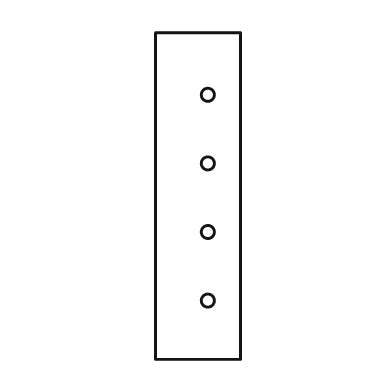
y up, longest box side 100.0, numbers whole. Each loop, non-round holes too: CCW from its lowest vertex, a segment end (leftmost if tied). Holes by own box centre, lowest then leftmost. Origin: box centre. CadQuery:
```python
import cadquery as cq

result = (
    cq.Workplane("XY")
    .moveTo(-13.0, -50.0)
    .lineTo(13.0, -50.0)
    .lineTo(13.0, 50.0)
    .lineTo(-13.0, 50.0)
    .close()
    .moveTo(3.0, -32.0)
    .circle(2.0)
    .moveTo(3.0, -11.0)
    .circle(2.0)
    .moveTo(3.0, 10.0)
    .circle(2.0)
    .moveTo(3.0, 31.0)
    .circle(2.0)
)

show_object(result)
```